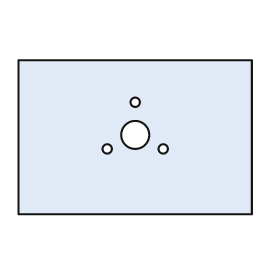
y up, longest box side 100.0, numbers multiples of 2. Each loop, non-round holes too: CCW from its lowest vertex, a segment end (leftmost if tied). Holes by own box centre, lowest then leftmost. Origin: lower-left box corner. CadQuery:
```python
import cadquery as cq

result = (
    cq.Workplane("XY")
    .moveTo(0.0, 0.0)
    .lineTo(100.0, 0.0)
    .lineTo(100.0, 66.0)
    .lineTo(0.0, 66.0)
    .close()
    .moveTo(38.0, 28.0)
    .circle(2.0)
    .moveTo(62.0, 28.0)
    .circle(2.0)
    .moveTo(50.0, 34.0)
    .circle(6.0)
    .moveTo(50.0, 48.0)
    .circle(2.0)
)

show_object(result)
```